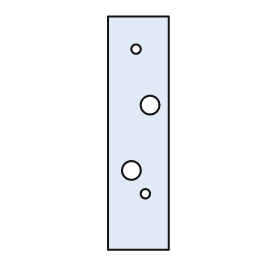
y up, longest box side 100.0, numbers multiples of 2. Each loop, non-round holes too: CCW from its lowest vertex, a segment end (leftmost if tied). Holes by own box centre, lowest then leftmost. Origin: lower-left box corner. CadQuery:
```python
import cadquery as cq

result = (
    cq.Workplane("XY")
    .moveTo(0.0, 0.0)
    .lineTo(26.0, 0.0)
    .lineTo(26.0, 100.0)
    .lineTo(0.0, 100.0)
    .close()
    .moveTo(16.0, 24.0)
    .circle(2.0)
    .moveTo(10.0, 34.0)
    .circle(4.0)
    .moveTo(18.0, 62.0)
    .circle(4.0)
    .moveTo(12.0, 86.0)
    .circle(2.0)
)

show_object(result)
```